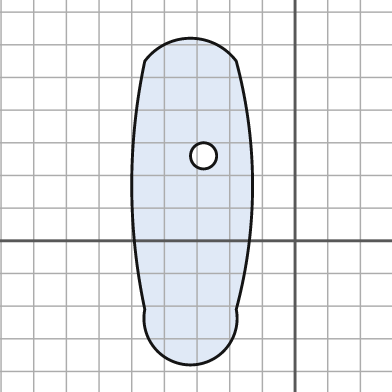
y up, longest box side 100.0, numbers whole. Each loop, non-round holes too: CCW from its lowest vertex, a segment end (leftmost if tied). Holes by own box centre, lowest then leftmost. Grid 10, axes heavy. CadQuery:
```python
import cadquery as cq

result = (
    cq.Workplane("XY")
    .moveTo(-46.0, -21.0)
    .threePointArc((-32.0, -38.0), (-18.0, -21.0))
    .threePointArc((-13.0, 17.0), (-18.0, 55.0))
    .threePointArc((-32.0, 62.0), (-46.0, 55.0))
    .threePointArc((-50.0, 17.0), (-46.0, -21.0))
    .close()
    .moveTo(-28.0, 26.0)
    .circle(4.0)
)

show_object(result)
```